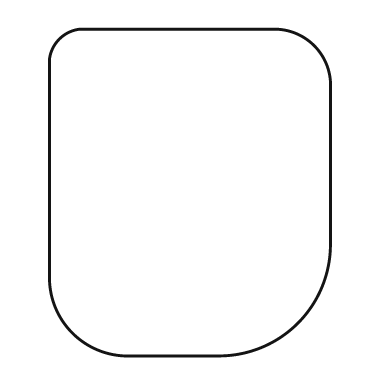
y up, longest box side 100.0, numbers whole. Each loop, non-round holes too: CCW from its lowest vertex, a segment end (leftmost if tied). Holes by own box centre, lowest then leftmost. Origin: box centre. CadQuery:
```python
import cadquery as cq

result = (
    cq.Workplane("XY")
    .moveTo(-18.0, -50.0)
    .lineTo(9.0, -50.0)
    .threePointArc((33.0, -40.0), (43.0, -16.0))
    .lineTo(43.0, 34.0)
    .threePointArc((38.0, 45.0), (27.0, 50.0))
    .lineTo(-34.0, 50.0)
    .threePointArc((-40.0, 47.0), (-43.0, 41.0))
    .lineTo(-43.0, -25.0)
    .threePointArc((-36.0, -43.0), (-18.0, -50.0))
    .close()
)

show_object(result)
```